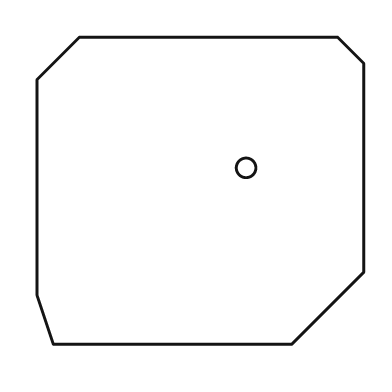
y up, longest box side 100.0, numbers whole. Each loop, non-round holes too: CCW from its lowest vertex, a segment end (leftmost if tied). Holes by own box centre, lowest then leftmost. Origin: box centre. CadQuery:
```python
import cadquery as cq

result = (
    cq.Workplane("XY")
    .moveTo(-45.0, -47.0)
    .lineTo(28.0, -47.0)
    .lineTo(50.0, -25.0)
    .lineTo(50.0, 39.0)
    .lineTo(42.0, 47.0)
    .lineTo(-37.0, 47.0)
    .lineTo(-50.0, 34.0)
    .lineTo(-50.0, -32.0)
    .close()
    .moveTo(14.0, 7.0)
    .circle(3.0)
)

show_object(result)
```